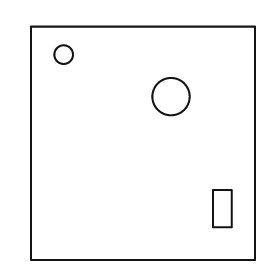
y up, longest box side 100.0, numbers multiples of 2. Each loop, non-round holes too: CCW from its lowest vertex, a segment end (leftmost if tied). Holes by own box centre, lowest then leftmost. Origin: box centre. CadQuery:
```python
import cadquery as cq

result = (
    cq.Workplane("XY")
    .moveTo(-48.0, -50.0)
    .lineTo(48.0, -50.0)
    .lineTo(48.0, 50.0)
    .lineTo(-48.0, 50.0)
    .close()
    .moveTo(30.0, -36.0)
    .lineTo(38.0, -36.0)
    .lineTo(38.0, -20.0)
    .lineTo(30.0, -20.0)
    .close()
    .moveTo(12.0, 20.0)
    .circle(8.0)
    .moveTo(-34.0, 38.0)
    .circle(4.0)
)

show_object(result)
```